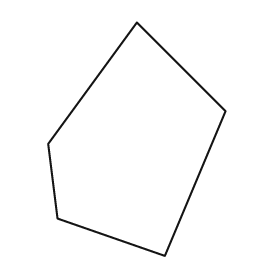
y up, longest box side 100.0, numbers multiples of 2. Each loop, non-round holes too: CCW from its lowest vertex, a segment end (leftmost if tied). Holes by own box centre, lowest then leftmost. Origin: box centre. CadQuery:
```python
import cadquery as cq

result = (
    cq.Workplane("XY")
    .moveTo(12.0, -50.0)
    .lineTo(38.0, 12.0)
    .lineTo(0.0, 50.0)
    .lineTo(-38.0, -2.0)
    .lineTo(-34.0, -34.0)
    .close()
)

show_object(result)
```